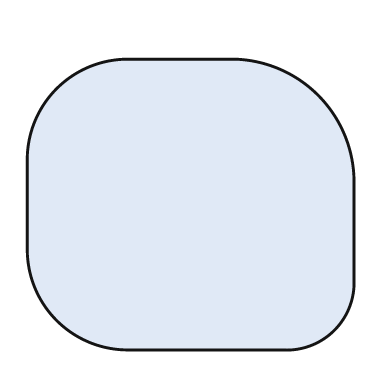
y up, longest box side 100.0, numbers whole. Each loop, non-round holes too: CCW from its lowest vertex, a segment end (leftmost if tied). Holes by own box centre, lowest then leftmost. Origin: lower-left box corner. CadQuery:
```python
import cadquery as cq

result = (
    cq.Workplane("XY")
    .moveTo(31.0, 0.0)
    .lineTo(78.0, 0.0)
    .threePointArc((94.0, 6.0), (100.0, 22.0))
    .lineTo(100.0, 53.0)
    .threePointArc((89.0, 78.0), (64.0, 89.0))
    .lineTo(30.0, 89.0)
    .threePointArc((9.0, 80.0), (0.0, 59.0))
    .lineTo(0.0, 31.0)
    .threePointArc((9.0, 9.0), (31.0, 0.0))
    .close()
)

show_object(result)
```